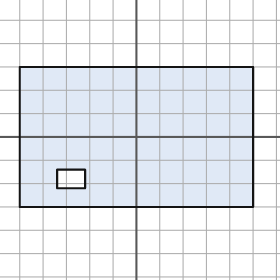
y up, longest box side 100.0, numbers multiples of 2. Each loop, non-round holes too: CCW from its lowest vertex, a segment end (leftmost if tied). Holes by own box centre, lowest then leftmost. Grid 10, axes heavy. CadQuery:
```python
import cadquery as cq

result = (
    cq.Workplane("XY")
    .moveTo(-50.0, -30.0)
    .lineTo(50.0, -30.0)
    .lineTo(50.0, 30.0)
    .lineTo(-50.0, 30.0)
    .close()
    .moveTo(-34.0, -22.0)
    .lineTo(-22.0, -22.0)
    .lineTo(-22.0, -14.0)
    .lineTo(-34.0, -14.0)
    .close()
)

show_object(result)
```